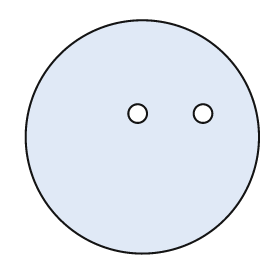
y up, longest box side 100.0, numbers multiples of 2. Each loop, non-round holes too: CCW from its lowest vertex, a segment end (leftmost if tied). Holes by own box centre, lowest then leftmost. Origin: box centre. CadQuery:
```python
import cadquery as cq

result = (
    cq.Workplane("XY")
    .moveTo(0.0, 0.0)
    .circle(50.0)
    .moveTo(-2.0, 10.0)
    .circle(4.0)
    .moveTo(26.0, 10.0)
    .circle(4.0)
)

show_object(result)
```